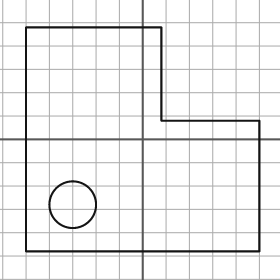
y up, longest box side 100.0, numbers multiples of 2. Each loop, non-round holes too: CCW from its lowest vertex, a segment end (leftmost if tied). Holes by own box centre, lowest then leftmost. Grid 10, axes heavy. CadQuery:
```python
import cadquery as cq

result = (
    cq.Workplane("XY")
    .moveTo(-50.0, -48.0)
    .lineTo(50.0, -48.0)
    .lineTo(50.0, 8.0)
    .lineTo(8.0, 8.0)
    .lineTo(8.0, 48.0)
    .lineTo(-50.0, 48.0)
    .close()
    .moveTo(-30.0, -28.0)
    .circle(10.0)
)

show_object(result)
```